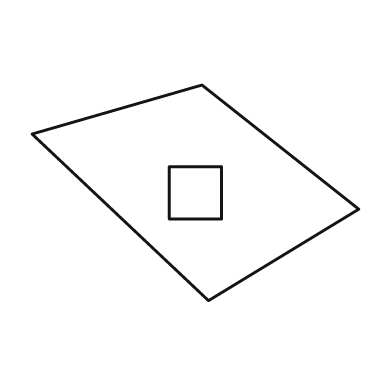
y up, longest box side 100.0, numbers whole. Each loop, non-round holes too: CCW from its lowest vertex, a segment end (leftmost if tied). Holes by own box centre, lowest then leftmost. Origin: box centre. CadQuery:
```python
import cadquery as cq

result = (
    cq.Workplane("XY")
    .moveTo(4.0, -33.0)
    .lineTo(50.0, -5.0)
    .lineTo(2.0, 33.0)
    .lineTo(-50.0, 18.0)
    .close()
    .moveTo(-8.0, -8.0)
    .lineTo(8.0, -8.0)
    .lineTo(8.0, 8.0)
    .lineTo(-8.0, 8.0)
    .close()
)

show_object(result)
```